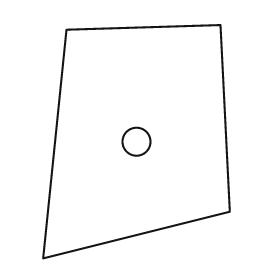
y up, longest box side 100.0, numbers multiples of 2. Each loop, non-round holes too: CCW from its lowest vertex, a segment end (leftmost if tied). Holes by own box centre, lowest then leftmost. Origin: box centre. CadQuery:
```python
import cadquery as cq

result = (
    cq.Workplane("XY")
    .moveTo(-40.0, -50.0)
    .lineTo(40.0, -30.0)
    .lineTo(36.0, 50.0)
    .lineTo(-30.0, 48.0)
    .close()
    .moveTo(0.0, 0.0)
    .circle(6.0)
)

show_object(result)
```